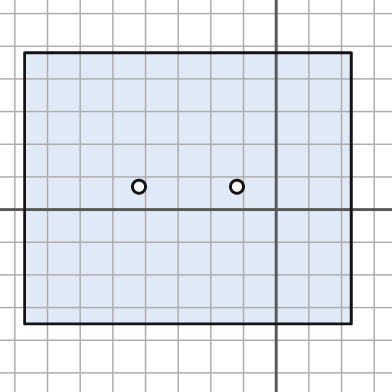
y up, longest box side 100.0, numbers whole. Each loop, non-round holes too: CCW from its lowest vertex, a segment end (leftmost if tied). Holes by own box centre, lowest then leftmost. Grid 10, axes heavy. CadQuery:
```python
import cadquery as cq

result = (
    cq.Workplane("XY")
    .moveTo(-77.0, -35.0)
    .lineTo(23.0, -35.0)
    .lineTo(23.0, 48.0)
    .lineTo(-77.0, 48.0)
    .close()
    .moveTo(-42.0, 7.0)
    .circle(2.0)
    .moveTo(-12.0, 7.0)
    .circle(2.0)
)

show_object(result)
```